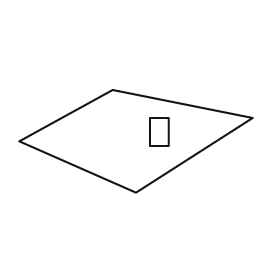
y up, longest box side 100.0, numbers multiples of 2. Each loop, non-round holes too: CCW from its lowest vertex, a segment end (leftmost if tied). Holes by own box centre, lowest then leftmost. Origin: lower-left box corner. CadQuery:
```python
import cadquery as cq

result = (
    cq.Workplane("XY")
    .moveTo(50.0, 0.0)
    .lineTo(100.0, 32.0)
    .lineTo(40.0, 44.0)
    .lineTo(0.0, 22.0)
    .close()
    .moveTo(56.0, 20.0)
    .lineTo(64.0, 20.0)
    .lineTo(64.0, 32.0)
    .lineTo(56.0, 32.0)
    .close()
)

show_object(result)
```